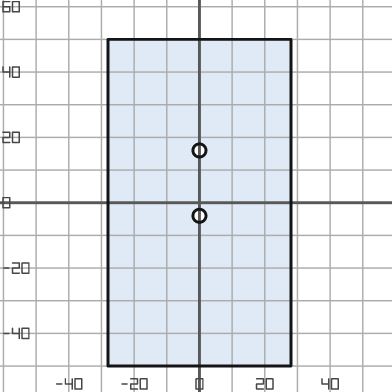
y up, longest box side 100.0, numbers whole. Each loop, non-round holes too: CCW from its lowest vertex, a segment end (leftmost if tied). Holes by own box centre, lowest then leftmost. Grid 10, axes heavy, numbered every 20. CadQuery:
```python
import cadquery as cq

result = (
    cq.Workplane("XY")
    .moveTo(-28.0, -50.0)
    .lineTo(28.0, -50.0)
    .lineTo(28.0, 50.0)
    .lineTo(-28.0, 50.0)
    .close()
    .moveTo(0.0, -4.0)
    .circle(2.0)
    .moveTo(0.0, 16.0)
    .circle(2.0)
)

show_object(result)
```